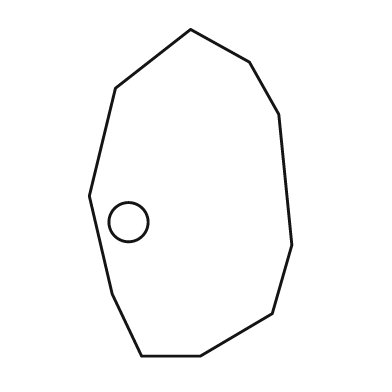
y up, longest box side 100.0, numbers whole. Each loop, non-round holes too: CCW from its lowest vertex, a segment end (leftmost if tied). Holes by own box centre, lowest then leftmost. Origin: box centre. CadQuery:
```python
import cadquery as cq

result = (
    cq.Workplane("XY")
    .moveTo(-15.0, -50.0)
    .lineTo(3.0, -50.0)
    .lineTo(25.0, -37.0)
    .lineTo(31.0, -16.0)
    .lineTo(27.0, 24.0)
    .lineTo(18.0, 40.0)
    .lineTo(0.0, 50.0)
    .lineTo(-23.0, 32.0)
    .lineTo(-31.0, -1.0)
    .lineTo(-24.0, -31.0)
    .close()
    .moveTo(-19.0, -9.0)
    .circle(6.0)
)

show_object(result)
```